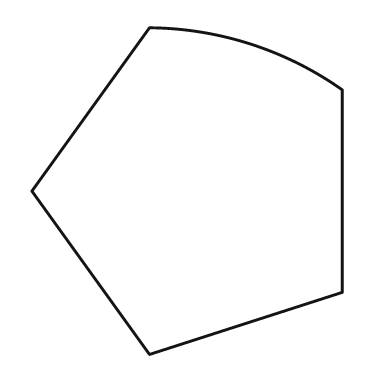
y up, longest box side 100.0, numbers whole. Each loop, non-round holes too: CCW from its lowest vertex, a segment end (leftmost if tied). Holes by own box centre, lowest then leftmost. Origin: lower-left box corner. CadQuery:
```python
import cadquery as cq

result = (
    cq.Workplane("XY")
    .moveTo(36.0, 0.0)
    .lineTo(95.0, 19.0)
    .lineTo(95.0, 81.0)
    .threePointArc((67.0, 95.0), (36.0, 100.0))
    .lineTo(0.0, 50.0)
    .close()
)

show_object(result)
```